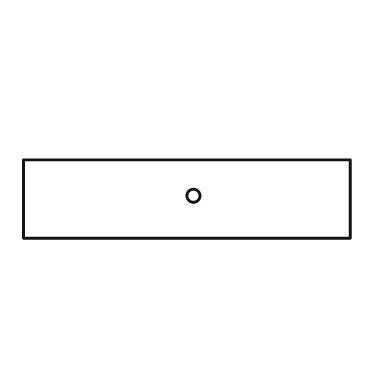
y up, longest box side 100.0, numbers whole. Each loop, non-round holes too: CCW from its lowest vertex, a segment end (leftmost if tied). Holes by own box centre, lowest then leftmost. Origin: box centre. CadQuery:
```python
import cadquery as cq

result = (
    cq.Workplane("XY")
    .moveTo(-50.0, -12.0)
    .lineTo(50.0, -12.0)
    .lineTo(50.0, 12.0)
    .lineTo(-50.0, 12.0)
    .close()
    .moveTo(2.0, 1.0)
    .circle(2.0)
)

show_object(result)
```